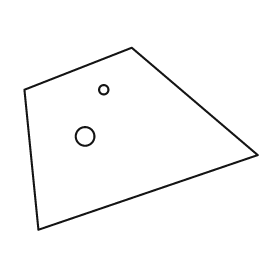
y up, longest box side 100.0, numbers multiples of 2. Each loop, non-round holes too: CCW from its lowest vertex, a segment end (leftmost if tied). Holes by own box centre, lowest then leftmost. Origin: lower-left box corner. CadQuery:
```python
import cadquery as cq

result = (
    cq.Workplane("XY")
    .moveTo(6.0, 0.0)
    .lineTo(100.0, 32.0)
    .lineTo(46.0, 78.0)
    .lineTo(0.0, 60.0)
    .close()
    .moveTo(26.0, 40.0)
    .circle(4.0)
    .moveTo(34.0, 60.0)
    .circle(2.0)
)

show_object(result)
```